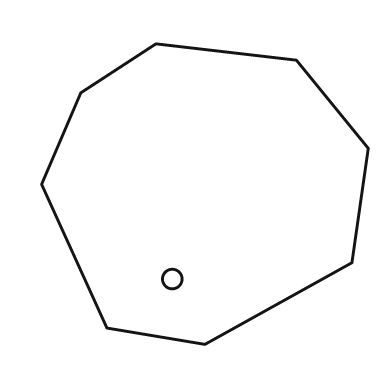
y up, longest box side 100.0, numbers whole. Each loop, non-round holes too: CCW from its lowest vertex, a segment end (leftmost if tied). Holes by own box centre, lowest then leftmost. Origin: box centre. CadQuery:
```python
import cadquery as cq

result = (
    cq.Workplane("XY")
    .moveTo(0.0, -46.0)
    .lineTo(45.0, -21.0)
    .lineTo(50.0, 14.0)
    .lineTo(28.0, 41.0)
    .lineTo(-15.0, 46.0)
    .lineTo(-38.0, 31.0)
    .lineTo(-50.0, 3.0)
    .lineTo(-30.0, -41.0)
    .close()
    .moveTo(-10.0, -26.0)
    .circle(3.0)
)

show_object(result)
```